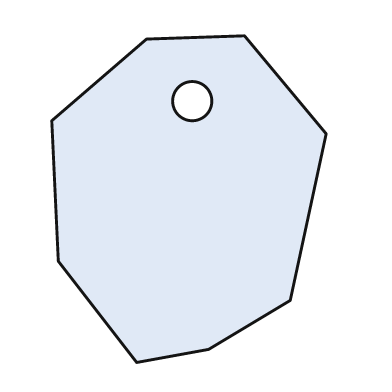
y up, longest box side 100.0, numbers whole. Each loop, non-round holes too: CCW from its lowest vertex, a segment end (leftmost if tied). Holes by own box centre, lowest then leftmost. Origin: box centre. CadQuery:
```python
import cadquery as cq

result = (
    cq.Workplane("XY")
    .moveTo(-16.0, -50.0)
    .lineTo(6.0, -46.0)
    .lineTo(31.0, -31.0)
    .lineTo(42.0, 20.0)
    .lineTo(17.0, 50.0)
    .lineTo(-13.0, 49.0)
    .lineTo(-42.0, 24.0)
    .lineTo(-40.0, -19.0)
    .close()
    .moveTo(1.0, 30.0)
    .circle(6.0)
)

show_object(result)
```